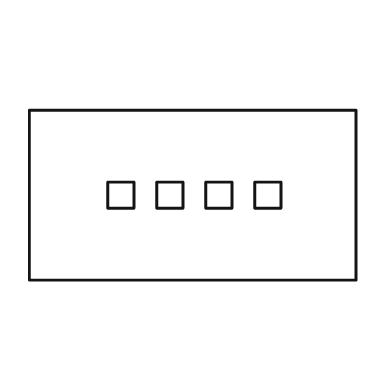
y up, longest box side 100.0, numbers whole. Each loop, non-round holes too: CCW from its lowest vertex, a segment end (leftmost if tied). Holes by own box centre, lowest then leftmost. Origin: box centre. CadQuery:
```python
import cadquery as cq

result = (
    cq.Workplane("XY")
    .moveTo(-50.0, -26.0)
    .lineTo(50.0, -26.0)
    .lineTo(50.0, 26.0)
    .lineTo(-50.0, 26.0)
    .close()
    .moveTo(-26.0, -4.0)
    .lineTo(-18.0, -4.0)
    .lineTo(-18.0, 4.0)
    .lineTo(-26.0, 4.0)
    .close()
    .moveTo(-11.0, -4.0)
    .lineTo(-3.0, -4.0)
    .lineTo(-3.0, 4.0)
    .lineTo(-11.0, 4.0)
    .close()
    .moveTo(4.0, -4.0)
    .lineTo(12.0, -4.0)
    .lineTo(12.0, 4.0)
    .lineTo(4.0, 4.0)
    .close()
    .moveTo(19.0, -4.0)
    .lineTo(27.0, -4.0)
    .lineTo(27.0, 4.0)
    .lineTo(19.0, 4.0)
    .close()
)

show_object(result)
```